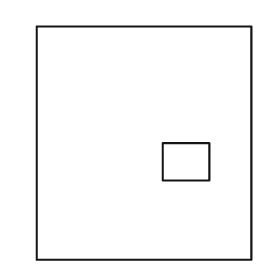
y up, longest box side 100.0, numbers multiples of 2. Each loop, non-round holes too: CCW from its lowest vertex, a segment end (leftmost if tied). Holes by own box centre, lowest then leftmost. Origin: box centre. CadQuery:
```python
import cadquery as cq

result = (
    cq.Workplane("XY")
    .moveTo(-46.0, -50.0)
    .lineTo(46.0, -50.0)
    .lineTo(46.0, 50.0)
    .lineTo(-46.0, 50.0)
    .close()
    .moveTo(8.0, -16.0)
    .lineTo(28.0, -16.0)
    .lineTo(28.0, 0.0)
    .lineTo(8.0, 0.0)
    .close()
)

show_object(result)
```